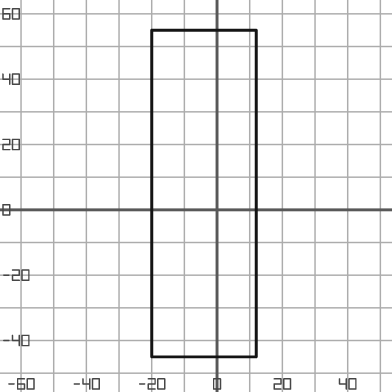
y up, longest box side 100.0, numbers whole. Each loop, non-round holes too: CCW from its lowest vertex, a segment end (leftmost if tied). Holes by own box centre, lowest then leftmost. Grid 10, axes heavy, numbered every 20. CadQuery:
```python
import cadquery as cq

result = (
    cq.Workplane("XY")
    .moveTo(-20.0, -45.0)
    .lineTo(12.0, -45.0)
    .lineTo(12.0, 55.0)
    .lineTo(-20.0, 55.0)
    .close()
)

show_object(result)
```